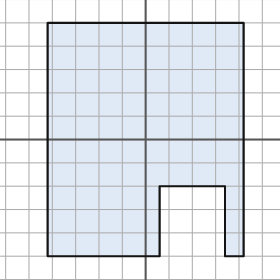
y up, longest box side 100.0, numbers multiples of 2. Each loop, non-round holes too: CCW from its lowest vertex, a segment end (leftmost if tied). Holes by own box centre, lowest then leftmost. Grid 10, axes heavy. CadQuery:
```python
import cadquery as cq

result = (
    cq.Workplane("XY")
    .moveTo(-42.0, -50.0)
    .lineTo(6.0, -50.0)
    .lineTo(6.0, -20.0)
    .lineTo(34.0, -20.0)
    .lineTo(34.0, -50.0)
    .lineTo(42.0, -50.0)
    .lineTo(42.0, 50.0)
    .lineTo(-42.0, 50.0)
    .close()
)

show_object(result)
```